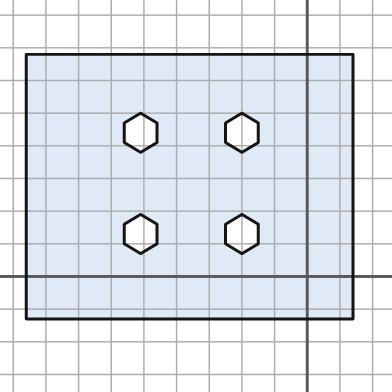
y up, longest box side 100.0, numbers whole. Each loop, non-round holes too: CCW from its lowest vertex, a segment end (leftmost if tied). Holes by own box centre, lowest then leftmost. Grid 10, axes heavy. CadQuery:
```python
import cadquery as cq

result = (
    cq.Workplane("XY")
    .moveTo(-86.0, -13.0)
    .lineTo(14.0, -13.0)
    .lineTo(14.0, 68.0)
    .lineTo(-86.0, 68.0)
    .close()
    .moveTo(-51.0, 7.0)
    .lineTo(-46.0, 10.0)
    .lineTo(-46.0, 16.0)
    .lineTo(-51.0, 19.0)
    .lineTo(-56.0, 16.0)
    .lineTo(-56.0, 10.0)
    .close()
    .moveTo(-20.0, 7.0)
    .lineTo(-15.0, 10.0)
    .lineTo(-15.0, 16.0)
    .lineTo(-20.0, 19.0)
    .lineTo(-25.0, 16.0)
    .lineTo(-25.0, 10.0)
    .close()
    .moveTo(-51.0, 38.0)
    .lineTo(-46.0, 41.0)
    .lineTo(-46.0, 47.0)
    .lineTo(-51.0, 50.0)
    .lineTo(-56.0, 47.0)
    .lineTo(-56.0, 41.0)
    .close()
    .moveTo(-20.0, 38.0)
    .lineTo(-15.0, 41.0)
    .lineTo(-15.0, 47.0)
    .lineTo(-20.0, 50.0)
    .lineTo(-25.0, 47.0)
    .lineTo(-25.0, 41.0)
    .close()
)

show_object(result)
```